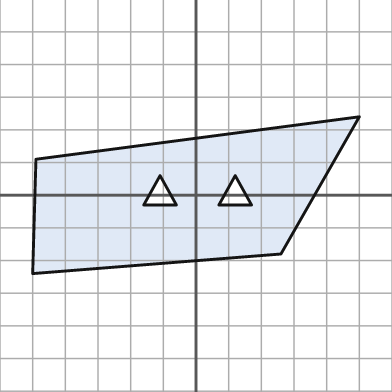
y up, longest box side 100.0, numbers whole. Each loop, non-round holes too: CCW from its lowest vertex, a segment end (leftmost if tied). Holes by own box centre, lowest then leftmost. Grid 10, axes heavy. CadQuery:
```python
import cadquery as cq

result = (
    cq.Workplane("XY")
    .moveTo(-50.0, -24.0)
    .lineTo(26.0, -18.0)
    .lineTo(50.0, 24.0)
    .lineTo(-49.0, 11.0)
    .close()
    .moveTo(-16.0, -3.0)
    .lineTo(-6.0, -3.0)
    .lineTo(-11.0, 6.0)
    .close()
    .moveTo(7.0, -3.0)
    .lineTo(17.0, -3.0)
    .lineTo(12.0, 6.0)
    .close()
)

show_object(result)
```